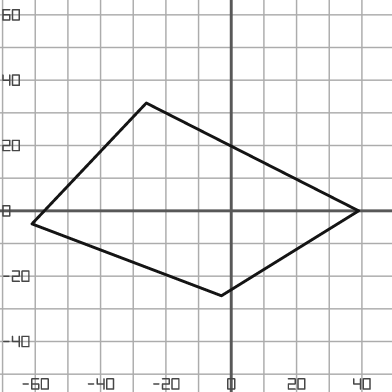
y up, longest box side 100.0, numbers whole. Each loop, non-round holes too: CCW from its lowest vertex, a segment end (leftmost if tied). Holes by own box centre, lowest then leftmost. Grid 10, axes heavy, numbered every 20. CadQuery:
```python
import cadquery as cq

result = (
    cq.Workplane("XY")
    .moveTo(-3.0, -26.0)
    .lineTo(39.0, 0.0)
    .lineTo(-26.0, 33.0)
    .lineTo(-61.0, -4.0)
    .close()
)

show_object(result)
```